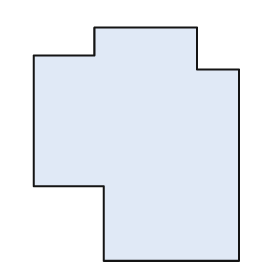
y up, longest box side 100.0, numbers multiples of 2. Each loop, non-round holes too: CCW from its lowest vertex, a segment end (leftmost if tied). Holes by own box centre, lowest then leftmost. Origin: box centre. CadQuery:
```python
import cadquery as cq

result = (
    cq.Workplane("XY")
    .moveTo(-14.0, -50.0)
    .lineTo(44.0, -50.0)
    .lineTo(44.0, 32.0)
    .lineTo(26.0, 32.0)
    .lineTo(26.0, 50.0)
    .lineTo(-18.0, 50.0)
    .lineTo(-18.0, 38.0)
    .lineTo(-44.0, 38.0)
    .lineTo(-44.0, -18.0)
    .lineTo(-14.0, -18.0)
    .close()
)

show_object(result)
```